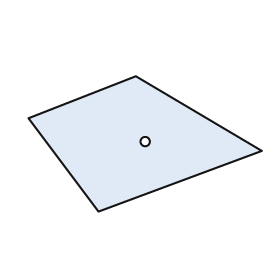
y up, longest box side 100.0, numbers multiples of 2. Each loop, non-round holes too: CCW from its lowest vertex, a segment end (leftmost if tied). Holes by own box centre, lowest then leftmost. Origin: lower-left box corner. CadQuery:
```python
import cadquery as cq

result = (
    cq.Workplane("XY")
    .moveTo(30.0, 0.0)
    .lineTo(100.0, 26.0)
    .lineTo(46.0, 58.0)
    .lineTo(0.0, 40.0)
    .close()
    .moveTo(50.0, 30.0)
    .circle(2.0)
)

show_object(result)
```